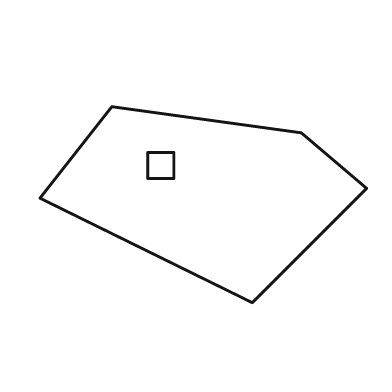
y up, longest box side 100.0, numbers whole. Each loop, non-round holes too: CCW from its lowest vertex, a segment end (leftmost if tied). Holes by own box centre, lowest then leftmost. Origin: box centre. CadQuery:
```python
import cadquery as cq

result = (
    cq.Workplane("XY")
    .moveTo(15.0, -30.0)
    .lineTo(50.0, 5.0)
    .lineTo(30.0, 22.0)
    .lineTo(-28.0, 30.0)
    .lineTo(-50.0, 2.0)
    .close()
    .moveTo(-17.0, 8.0)
    .lineTo(-9.0, 8.0)
    .lineTo(-9.0, 16.0)
    .lineTo(-17.0, 16.0)
    .close()
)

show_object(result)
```